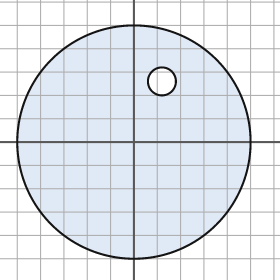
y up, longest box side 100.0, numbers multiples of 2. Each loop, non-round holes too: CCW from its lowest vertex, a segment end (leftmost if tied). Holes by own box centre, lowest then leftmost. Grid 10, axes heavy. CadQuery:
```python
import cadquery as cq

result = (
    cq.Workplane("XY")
    .moveTo(0.0, 0.0)
    .circle(50.0)
    .moveTo(12.0, 26.0)
    .circle(6.0)
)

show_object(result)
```